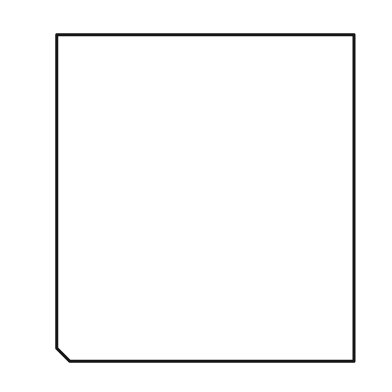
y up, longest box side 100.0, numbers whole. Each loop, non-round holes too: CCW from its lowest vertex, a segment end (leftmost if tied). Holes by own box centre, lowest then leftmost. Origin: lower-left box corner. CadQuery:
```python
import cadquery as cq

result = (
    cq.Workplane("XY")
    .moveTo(4.0, 0.0)
    .lineTo(91.0, 0.0)
    .lineTo(91.0, 100.0)
    .lineTo(0.0, 100.0)
    .lineTo(0.0, 4.0)
    .close()
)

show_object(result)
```